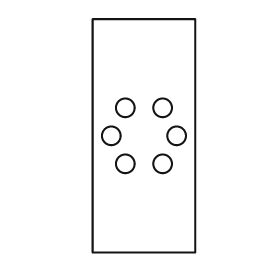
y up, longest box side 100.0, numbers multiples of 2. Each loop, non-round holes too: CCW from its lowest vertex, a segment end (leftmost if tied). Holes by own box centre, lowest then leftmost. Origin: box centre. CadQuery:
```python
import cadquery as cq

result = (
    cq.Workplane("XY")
    .moveTo(-22.0, -50.0)
    .lineTo(22.0, -50.0)
    .lineTo(22.0, 50.0)
    .lineTo(-22.0, 50.0)
    .close()
    .moveTo(-8.0, -12.0)
    .circle(4.0)
    .moveTo(8.0, -12.0)
    .circle(4.0)
    .moveTo(-14.0, 0.0)
    .circle(4.0)
    .moveTo(14.0, 0.0)
    .circle(4.0)
    .moveTo(-8.0, 12.0)
    .circle(4.0)
    .moveTo(8.0, 12.0)
    .circle(4.0)
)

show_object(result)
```